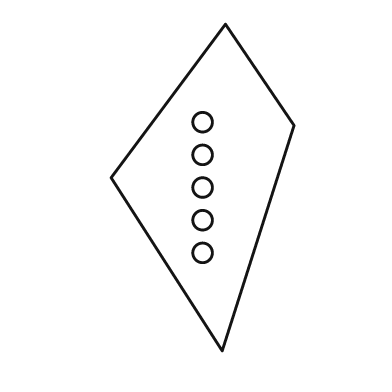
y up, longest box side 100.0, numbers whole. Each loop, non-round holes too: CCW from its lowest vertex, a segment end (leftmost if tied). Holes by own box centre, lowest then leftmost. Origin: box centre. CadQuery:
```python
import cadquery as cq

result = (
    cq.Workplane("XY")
    .moveTo(6.0, -50.0)
    .lineTo(28.0, 19.0)
    .lineTo(7.0, 50.0)
    .lineTo(-28.0, 3.0)
    .close()
    .moveTo(0.0, -20.0)
    .circle(3.0)
    .moveTo(0.0, -10.0)
    .circle(3.0)
    .moveTo(0.0, 0.0)
    .circle(3.0)
    .moveTo(0.0, 10.0)
    .circle(3.0)
    .moveTo(0.0, 20.0)
    .circle(3.0)
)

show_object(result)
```